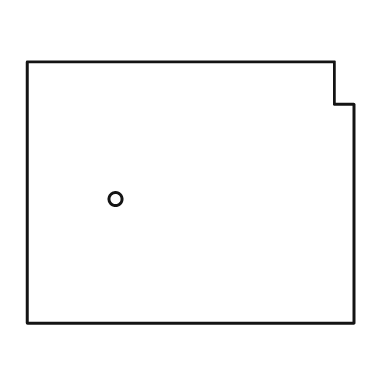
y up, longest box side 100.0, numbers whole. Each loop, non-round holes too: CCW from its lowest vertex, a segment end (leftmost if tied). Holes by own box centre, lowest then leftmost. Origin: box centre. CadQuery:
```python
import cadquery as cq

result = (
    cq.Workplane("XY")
    .moveTo(-50.0, -40.0)
    .lineTo(50.0, -40.0)
    .lineTo(50.0, 27.0)
    .lineTo(44.0, 27.0)
    .lineTo(44.0, 40.0)
    .lineTo(-50.0, 40.0)
    .close()
    .moveTo(-23.0, -2.0)
    .circle(2.0)
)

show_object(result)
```